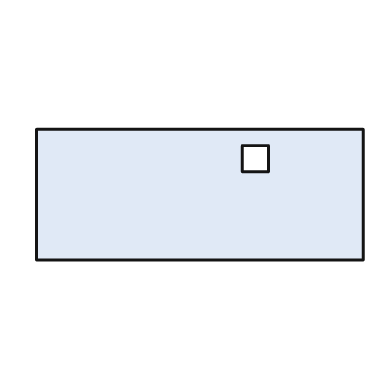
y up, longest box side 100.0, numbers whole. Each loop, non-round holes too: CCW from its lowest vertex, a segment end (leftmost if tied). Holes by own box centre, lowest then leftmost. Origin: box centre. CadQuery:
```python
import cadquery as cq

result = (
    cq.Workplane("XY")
    .moveTo(-50.0, -20.0)
    .lineTo(50.0, -20.0)
    .lineTo(50.0, 20.0)
    .lineTo(-50.0, 20.0)
    .close()
    .moveTo(13.0, 7.0)
    .lineTo(21.0, 7.0)
    .lineTo(21.0, 15.0)
    .lineTo(13.0, 15.0)
    .close()
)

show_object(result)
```